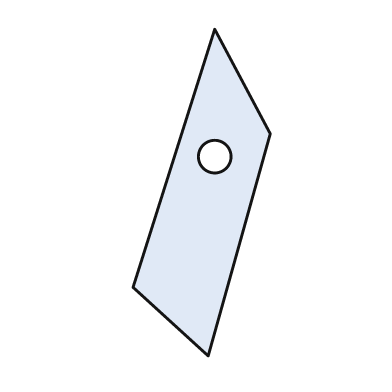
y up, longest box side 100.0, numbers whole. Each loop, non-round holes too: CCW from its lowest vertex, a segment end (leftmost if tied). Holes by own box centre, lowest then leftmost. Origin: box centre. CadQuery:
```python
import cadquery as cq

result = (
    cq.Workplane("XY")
    .moveTo(2.0, -50.0)
    .lineTo(21.0, 18.0)
    .lineTo(4.0, 50.0)
    .lineTo(-21.0, -29.0)
    .close()
    .moveTo(4.0, 11.0)
    .circle(5.0)
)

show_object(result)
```